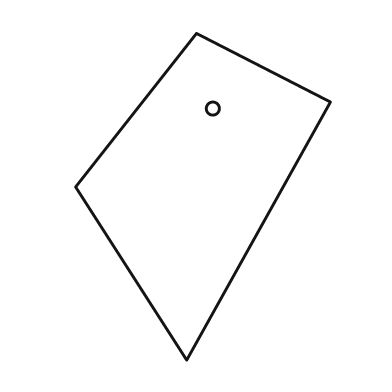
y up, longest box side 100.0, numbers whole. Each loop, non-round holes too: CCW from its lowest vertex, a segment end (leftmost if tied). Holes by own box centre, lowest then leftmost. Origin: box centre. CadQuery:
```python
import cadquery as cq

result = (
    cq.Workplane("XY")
    .moveTo(-5.0, -50.0)
    .lineTo(39.0, 29.0)
    .lineTo(-2.0, 50.0)
    .lineTo(-39.0, 3.0)
    .close()
    .moveTo(3.0, 27.0)
    .circle(2.0)
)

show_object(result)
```